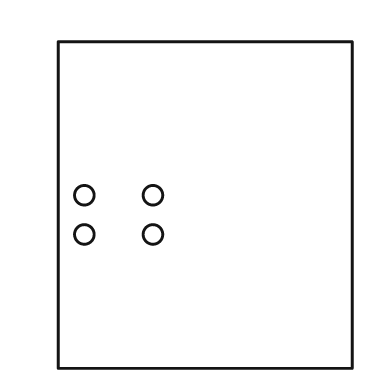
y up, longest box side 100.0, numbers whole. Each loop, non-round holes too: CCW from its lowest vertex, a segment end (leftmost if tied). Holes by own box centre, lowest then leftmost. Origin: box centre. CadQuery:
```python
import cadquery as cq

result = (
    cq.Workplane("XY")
    .moveTo(-45.0, -50.0)
    .lineTo(45.0, -50.0)
    .lineTo(45.0, 50.0)
    .lineTo(-45.0, 50.0)
    .close()
    .moveTo(-37.0, -9.0)
    .circle(3.0)
    .moveTo(-16.0, -9.0)
    .circle(3.0)
    .moveTo(-37.0, 3.0)
    .circle(3.0)
    .moveTo(-16.0, 3.0)
    .circle(3.0)
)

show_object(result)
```